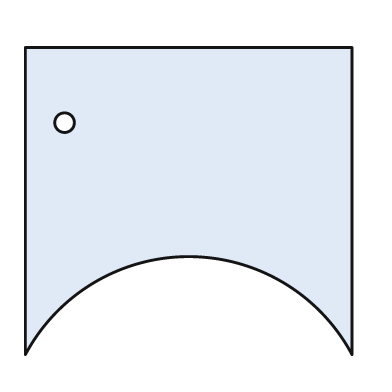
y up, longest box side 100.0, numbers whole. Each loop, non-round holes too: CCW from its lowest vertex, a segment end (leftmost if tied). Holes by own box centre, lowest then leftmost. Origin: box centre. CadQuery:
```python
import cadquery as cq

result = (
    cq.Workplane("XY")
    .moveTo(-50.0, -47.0)
    .threePointArc((0.0, -17.0), (50.0, -47.0))
    .lineTo(50.0, 47.0)
    .lineTo(-50.0, 47.0)
    .close()
    .moveTo(-38.0, 24.0)
    .circle(3.0)
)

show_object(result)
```